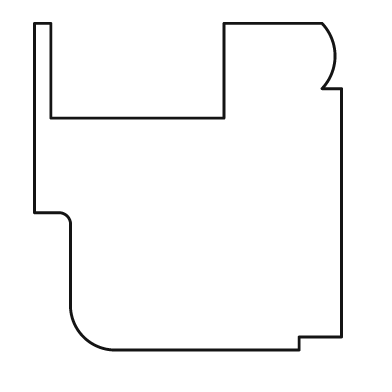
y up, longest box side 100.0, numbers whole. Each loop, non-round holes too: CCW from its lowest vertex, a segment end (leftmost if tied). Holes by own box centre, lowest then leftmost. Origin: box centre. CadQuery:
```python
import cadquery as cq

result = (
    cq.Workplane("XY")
    .moveTo(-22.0, -50.0)
    .lineTo(34.0, -50.0)
    .lineTo(34.0, -46.0)
    .lineTo(47.0, -46.0)
    .lineTo(47.0, 30.0)
    .lineTo(41.0, 30.0)
    .threePointArc((45.0, 40.0), (41.0, 50.0))
    .lineTo(11.0, 50.0)
    .lineTo(11.0, 21.0)
    .lineTo(-42.0, 21.0)
    .lineTo(-42.0, 50.0)
    .lineTo(-47.0, 50.0)
    .lineTo(-47.0, -8.0)
    .lineTo(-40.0, -8.0)
    .threePointArc((-37.0, -9.0), (-36.0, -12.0))
    .lineTo(-36.0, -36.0)
    .threePointArc((-32.0, -46.0), (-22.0, -50.0))
    .close()
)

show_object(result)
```